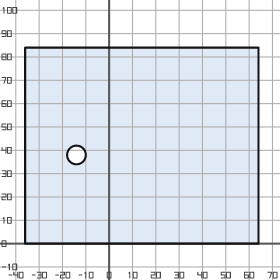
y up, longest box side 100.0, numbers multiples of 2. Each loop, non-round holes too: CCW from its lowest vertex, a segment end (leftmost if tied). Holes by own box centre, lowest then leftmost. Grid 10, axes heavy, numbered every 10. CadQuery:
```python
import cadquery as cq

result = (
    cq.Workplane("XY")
    .moveTo(-36.0, 0.0)
    .lineTo(64.0, 0.0)
    .lineTo(64.0, 84.0)
    .lineTo(-36.0, 84.0)
    .close()
    .moveTo(-14.0, 38.0)
    .circle(4.0)
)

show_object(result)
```